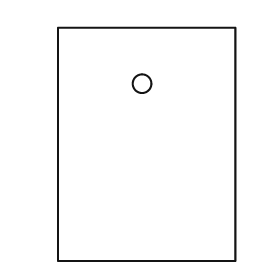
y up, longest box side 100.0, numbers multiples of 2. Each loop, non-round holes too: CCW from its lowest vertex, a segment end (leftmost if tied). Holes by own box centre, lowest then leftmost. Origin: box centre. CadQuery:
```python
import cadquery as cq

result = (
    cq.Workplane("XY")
    .moveTo(-38.0, -50.0)
    .lineTo(38.0, -50.0)
    .lineTo(38.0, 50.0)
    .lineTo(-38.0, 50.0)
    .close()
    .moveTo(-2.0, 26.0)
    .circle(4.0)
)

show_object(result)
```